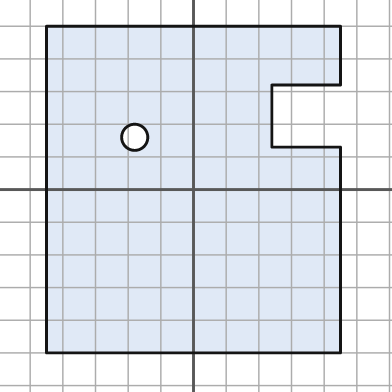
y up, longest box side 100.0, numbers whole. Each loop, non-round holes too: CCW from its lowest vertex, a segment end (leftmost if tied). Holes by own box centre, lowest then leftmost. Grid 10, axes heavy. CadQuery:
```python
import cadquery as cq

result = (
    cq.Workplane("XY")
    .moveTo(-45.0, -50.0)
    .lineTo(45.0, -50.0)
    .lineTo(45.0, 13.0)
    .lineTo(24.0, 13.0)
    .lineTo(24.0, 32.0)
    .lineTo(45.0, 32.0)
    .lineTo(45.0, 50.0)
    .lineTo(-45.0, 50.0)
    .close()
    .moveTo(-18.0, 16.0)
    .circle(4.0)
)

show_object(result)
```